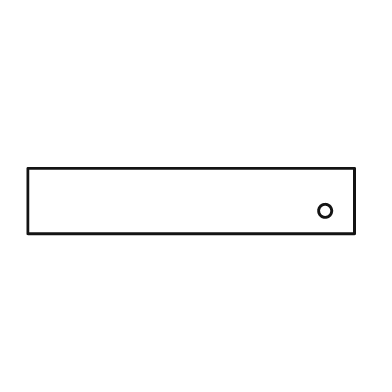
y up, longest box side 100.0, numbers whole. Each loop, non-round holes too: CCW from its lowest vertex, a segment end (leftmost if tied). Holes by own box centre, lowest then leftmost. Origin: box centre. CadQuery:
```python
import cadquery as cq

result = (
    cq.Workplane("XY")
    .moveTo(-50.0, -10.0)
    .lineTo(50.0, -10.0)
    .lineTo(50.0, 10.0)
    .lineTo(-50.0, 10.0)
    .close()
    .moveTo(41.0, -3.0)
    .circle(2.0)
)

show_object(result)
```